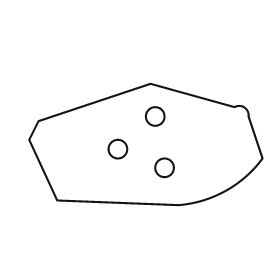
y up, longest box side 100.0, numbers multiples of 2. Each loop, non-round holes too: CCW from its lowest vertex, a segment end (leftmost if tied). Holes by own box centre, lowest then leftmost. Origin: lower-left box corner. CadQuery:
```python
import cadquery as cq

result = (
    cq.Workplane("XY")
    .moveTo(64.0, 0.0)
    .threePointArc((84.0, 6.0), (100.0, 20.0))
    .lineTo(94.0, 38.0)
    .threePointArc((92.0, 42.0), (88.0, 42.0))
    .lineTo(52.0, 52.0)
    .lineTo(4.0, 36.0)
    .lineTo(0.0, 28.0)
    .lineTo(12.0, 2.0)
    .close()
    .moveTo(58.0, 16.0)
    .circle(4.0)
    .moveTo(38.0, 24.0)
    .circle(4.0)
    .moveTo(54.0, 38.0)
    .circle(4.0)
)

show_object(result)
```